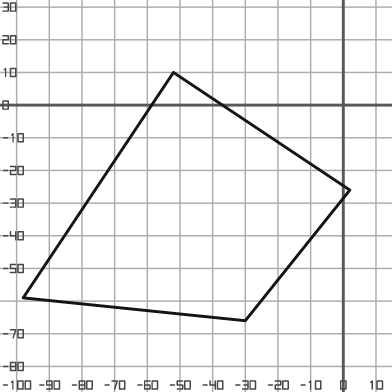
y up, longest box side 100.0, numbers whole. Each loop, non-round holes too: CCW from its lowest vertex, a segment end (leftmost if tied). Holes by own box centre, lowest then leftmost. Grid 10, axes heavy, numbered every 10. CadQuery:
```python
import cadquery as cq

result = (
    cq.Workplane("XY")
    .moveTo(-30.0, -66.0)
    .lineTo(2.0, -26.0)
    .lineTo(-52.0, 10.0)
    .lineTo(-98.0, -59.0)
    .close()
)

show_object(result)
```